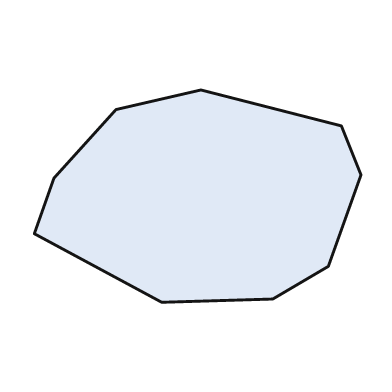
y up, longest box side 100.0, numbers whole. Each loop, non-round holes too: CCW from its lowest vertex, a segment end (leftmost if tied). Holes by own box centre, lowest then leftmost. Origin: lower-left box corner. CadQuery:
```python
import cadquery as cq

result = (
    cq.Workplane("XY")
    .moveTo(39.0, 0.0)
    .lineTo(73.0, 1.0)
    .lineTo(90.0, 11.0)
    .lineTo(100.0, 39.0)
    .lineTo(94.0, 54.0)
    .lineTo(51.0, 65.0)
    .lineTo(25.0, 59.0)
    .lineTo(6.0, 38.0)
    .lineTo(0.0, 21.0)
    .close()
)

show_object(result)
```